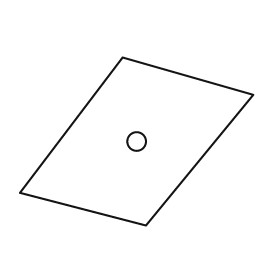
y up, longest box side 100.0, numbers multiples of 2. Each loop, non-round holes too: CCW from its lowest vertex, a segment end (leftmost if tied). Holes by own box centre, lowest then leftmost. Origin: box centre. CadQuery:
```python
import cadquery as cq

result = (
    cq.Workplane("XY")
    .moveTo(4.0, -36.0)
    .lineTo(50.0, 20.0)
    .lineTo(-6.0, 36.0)
    .lineTo(-50.0, -22.0)
    .close()
    .moveTo(0.0, 0.0)
    .circle(4.0)
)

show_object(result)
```